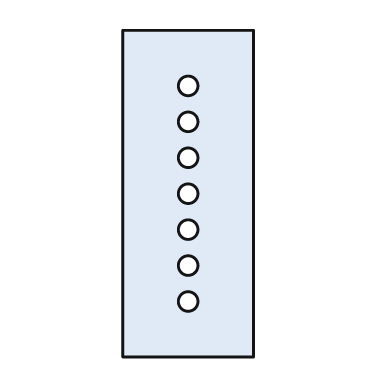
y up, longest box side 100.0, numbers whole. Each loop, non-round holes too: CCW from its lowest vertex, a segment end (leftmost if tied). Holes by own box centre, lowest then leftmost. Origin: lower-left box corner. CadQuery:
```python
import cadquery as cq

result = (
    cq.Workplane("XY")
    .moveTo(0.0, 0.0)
    .lineTo(40.0, 0.0)
    .lineTo(40.0, 100.0)
    .lineTo(0.0, 100.0)
    .close()
    .moveTo(20.0, 17.0)
    .circle(3.0)
    .moveTo(20.0, 28.0)
    .circle(3.0)
    .moveTo(20.0, 39.0)
    .circle(3.0)
    .moveTo(20.0, 50.0)
    .circle(3.0)
    .moveTo(20.0, 61.0)
    .circle(3.0)
    .moveTo(20.0, 72.0)
    .circle(3.0)
    .moveTo(20.0, 83.0)
    .circle(3.0)
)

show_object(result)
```